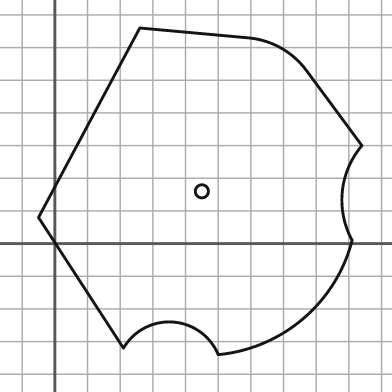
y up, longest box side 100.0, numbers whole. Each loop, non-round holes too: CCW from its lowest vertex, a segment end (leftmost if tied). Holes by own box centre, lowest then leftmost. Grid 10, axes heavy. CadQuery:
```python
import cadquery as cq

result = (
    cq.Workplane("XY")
    .moveTo(50.0, -34.0)
    .threePointArc((76.0, -23.0), (91.0, 1.0))
    .threePointArc((88.0, 16.0), (94.0, 30.0))
    .lineTo(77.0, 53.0)
    .threePointArc((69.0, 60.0), (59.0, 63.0))
    .lineTo(26.0, 66.0)
    .lineTo(-5.0, 8.0)
    .lineTo(21.0, -32.0)
    .threePointArc((36.0, -24.0), (50.0, -34.0))
    .close()
    .moveTo(45.0, 16.0)
    .circle(2.0)
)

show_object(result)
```